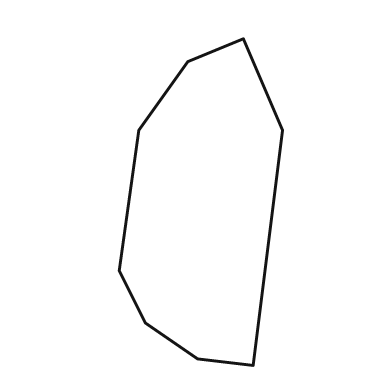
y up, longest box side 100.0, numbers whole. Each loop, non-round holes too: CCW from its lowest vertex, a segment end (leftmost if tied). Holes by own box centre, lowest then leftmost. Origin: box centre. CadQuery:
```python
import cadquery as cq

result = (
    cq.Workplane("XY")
    .moveTo(16.0, -50.0)
    .lineTo(25.0, 22.0)
    .lineTo(13.0, 50.0)
    .lineTo(-4.0, 43.0)
    .lineTo(-19.0, 22.0)
    .lineTo(-25.0, -21.0)
    .lineTo(-17.0, -37.0)
    .lineTo(-1.0, -48.0)
    .close()
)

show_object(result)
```